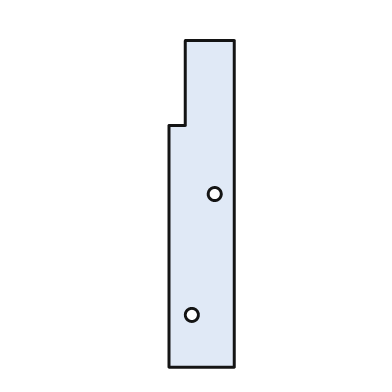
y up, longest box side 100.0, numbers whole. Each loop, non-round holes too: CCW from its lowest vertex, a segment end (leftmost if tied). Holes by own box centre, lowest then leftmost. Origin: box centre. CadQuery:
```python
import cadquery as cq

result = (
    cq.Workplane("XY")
    .moveTo(-10.0, -50.0)
    .lineTo(10.0, -50.0)
    .lineTo(10.0, 50.0)
    .lineTo(-5.0, 50.0)
    .lineTo(-5.0, 24.0)
    .lineTo(-10.0, 24.0)
    .close()
    .moveTo(-3.0, -34.0)
    .circle(2.0)
    .moveTo(4.0, 3.0)
    .circle(2.0)
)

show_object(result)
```